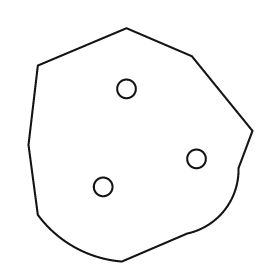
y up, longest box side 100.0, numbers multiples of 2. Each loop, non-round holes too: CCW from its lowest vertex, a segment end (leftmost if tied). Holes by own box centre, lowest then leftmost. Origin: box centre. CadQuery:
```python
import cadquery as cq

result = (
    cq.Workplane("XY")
    .moveTo(-8.0, -50.0)
    .lineTo(20.0, -38.0)
    .threePointArc((36.0, -28.0), (42.0, -10.0))
    .lineTo(48.0, 6.0)
    .lineTo(22.0, 38.0)
    .lineTo(-6.0, 50.0)
    .lineTo(-44.0, 34.0)
    .lineTo(-48.0, 0.0)
    .lineTo(-44.0, -30.0)
    .threePointArc((-28.0, -44.0), (-8.0, -50.0))
    .close()
    .moveTo(-16.0, -18.0)
    .circle(4.0)
    .moveTo(24.0, -6.0)
    .circle(4.0)
    .moveTo(-6.0, 24.0)
    .circle(4.0)
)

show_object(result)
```